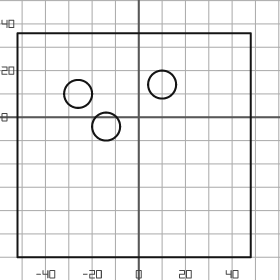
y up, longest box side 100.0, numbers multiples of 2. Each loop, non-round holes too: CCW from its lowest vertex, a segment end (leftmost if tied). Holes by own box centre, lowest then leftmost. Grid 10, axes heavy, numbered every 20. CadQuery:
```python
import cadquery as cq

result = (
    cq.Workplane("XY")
    .moveTo(-52.0, -60.0)
    .lineTo(48.0, -60.0)
    .lineTo(48.0, 36.0)
    .lineTo(-52.0, 36.0)
    .close()
    .moveTo(-14.0, -4.0)
    .circle(6.0)
    .moveTo(-26.0, 10.0)
    .circle(6.0)
    .moveTo(10.0, 14.0)
    .circle(6.0)
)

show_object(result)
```